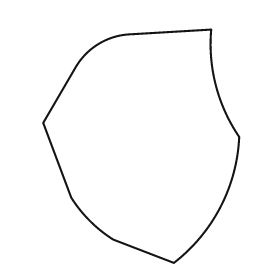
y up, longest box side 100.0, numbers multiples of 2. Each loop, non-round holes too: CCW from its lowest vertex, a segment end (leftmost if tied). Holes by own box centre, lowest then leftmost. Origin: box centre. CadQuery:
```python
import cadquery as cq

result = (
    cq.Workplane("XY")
    .moveTo(14.0, -50.0)
    .threePointArc((34.0, -26.0), (42.0, 4.0))
    .threePointArc((32.0, 26.0), (30.0, 50.0))
    .lineTo(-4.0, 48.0)
    .threePointArc((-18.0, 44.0), (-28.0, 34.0))
    .lineTo(-42.0, 10.0)
    .lineTo(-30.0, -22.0)
    .threePointArc((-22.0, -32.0), (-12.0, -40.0))
    .close()
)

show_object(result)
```